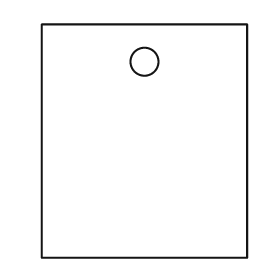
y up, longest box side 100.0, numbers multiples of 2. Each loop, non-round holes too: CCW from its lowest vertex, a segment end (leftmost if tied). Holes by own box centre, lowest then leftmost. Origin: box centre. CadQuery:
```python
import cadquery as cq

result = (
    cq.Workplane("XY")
    .moveTo(-44.0, -50.0)
    .lineTo(44.0, -50.0)
    .lineTo(44.0, 50.0)
    .lineTo(-44.0, 50.0)
    .close()
    .moveTo(0.0, 34.0)
    .circle(6.0)
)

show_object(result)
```